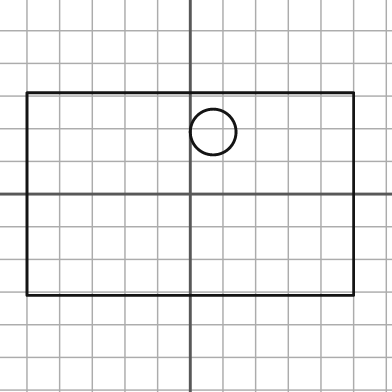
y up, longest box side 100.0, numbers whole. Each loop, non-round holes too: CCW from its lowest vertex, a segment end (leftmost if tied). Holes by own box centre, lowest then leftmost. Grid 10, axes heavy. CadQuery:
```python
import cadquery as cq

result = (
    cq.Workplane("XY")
    .moveTo(-50.0, -31.0)
    .lineTo(50.0, -31.0)
    .lineTo(50.0, 31.0)
    .lineTo(-50.0, 31.0)
    .close()
    .moveTo(7.0, 19.0)
    .circle(7.0)
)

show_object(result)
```